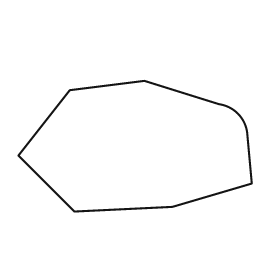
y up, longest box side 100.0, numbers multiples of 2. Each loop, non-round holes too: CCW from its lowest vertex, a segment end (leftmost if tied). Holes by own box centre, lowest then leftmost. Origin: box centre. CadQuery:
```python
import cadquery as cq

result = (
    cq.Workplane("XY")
    .moveTo(-26.0, -28.0)
    .lineTo(16.0, -26.0)
    .lineTo(50.0, -16.0)
    .lineTo(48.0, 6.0)
    .threePointArc((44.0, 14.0), (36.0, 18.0))
    .lineTo(4.0, 28.0)
    .lineTo(-28.0, 24.0)
    .lineTo(-50.0, -4.0)
    .close()
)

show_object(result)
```